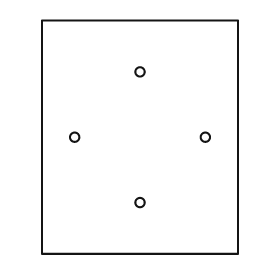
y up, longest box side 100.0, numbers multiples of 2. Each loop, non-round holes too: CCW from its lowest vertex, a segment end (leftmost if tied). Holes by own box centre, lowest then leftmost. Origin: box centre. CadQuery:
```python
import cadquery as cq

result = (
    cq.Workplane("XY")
    .moveTo(-42.0, -50.0)
    .lineTo(42.0, -50.0)
    .lineTo(42.0, 50.0)
    .lineTo(-42.0, 50.0)
    .close()
    .moveTo(0.0, -28.0)
    .circle(2.0)
    .moveTo(-28.0, 0.0)
    .circle(2.0)
    .moveTo(28.0, 0.0)
    .circle(2.0)
    .moveTo(0.0, 28.0)
    .circle(2.0)
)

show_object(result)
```